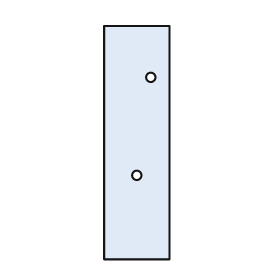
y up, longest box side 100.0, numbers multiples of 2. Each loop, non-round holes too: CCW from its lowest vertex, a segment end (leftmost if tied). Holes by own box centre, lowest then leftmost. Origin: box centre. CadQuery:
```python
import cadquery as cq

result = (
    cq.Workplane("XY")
    .moveTo(-14.0, -50.0)
    .lineTo(14.0, -50.0)
    .lineTo(14.0, 50.0)
    .lineTo(-14.0, 50.0)
    .close()
    .moveTo(0.0, -14.0)
    .circle(2.0)
    .moveTo(6.0, 28.0)
    .circle(2.0)
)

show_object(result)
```